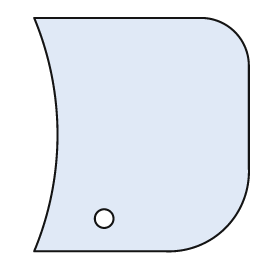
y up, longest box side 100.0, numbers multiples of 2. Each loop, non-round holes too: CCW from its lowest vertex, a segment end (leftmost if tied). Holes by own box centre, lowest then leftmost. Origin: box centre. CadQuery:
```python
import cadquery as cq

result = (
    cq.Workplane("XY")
    .moveTo(-46.0, -50.0)
    .lineTo(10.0, -50.0)
    .threePointArc((36.0, -40.0), (46.0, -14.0))
    .lineTo(46.0, 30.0)
    .threePointArc((40.0, 44.0), (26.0, 50.0))
    .lineTo(-46.0, 50.0)
    .threePointArc((-36.0, 0.0), (-46.0, -50.0))
    .close()
    .moveTo(-16.0, -36.0)
    .circle(4.0)
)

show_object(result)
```